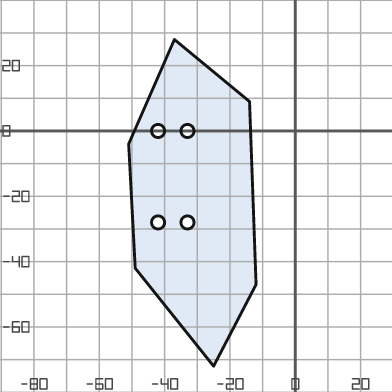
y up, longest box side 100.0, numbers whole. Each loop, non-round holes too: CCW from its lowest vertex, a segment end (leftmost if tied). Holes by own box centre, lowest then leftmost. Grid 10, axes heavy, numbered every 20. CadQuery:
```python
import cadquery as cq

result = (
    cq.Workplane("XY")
    .moveTo(-25.0, -72.0)
    .lineTo(-12.0, -47.0)
    .lineTo(-14.0, 9.0)
    .lineTo(-37.0, 28.0)
    .lineTo(-51.0, -4.0)
    .lineTo(-49.0, -42.0)
    .close()
    .moveTo(-42.0, -28.0)
    .circle(2.0)
    .moveTo(-33.0, -28.0)
    .circle(2.0)
    .moveTo(-42.0, 0.0)
    .circle(2.0)
    .moveTo(-33.0, 0.0)
    .circle(2.0)
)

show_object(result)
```